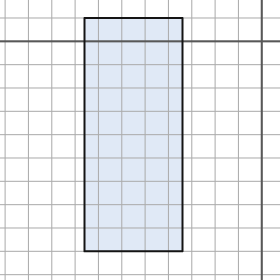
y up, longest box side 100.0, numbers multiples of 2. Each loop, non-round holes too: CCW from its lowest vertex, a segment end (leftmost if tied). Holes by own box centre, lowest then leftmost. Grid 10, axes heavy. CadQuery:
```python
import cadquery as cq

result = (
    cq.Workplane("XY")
    .moveTo(-76.0, -90.0)
    .lineTo(-34.0, -90.0)
    .lineTo(-34.0, 10.0)
    .lineTo(-76.0, 10.0)
    .close()
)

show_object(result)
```